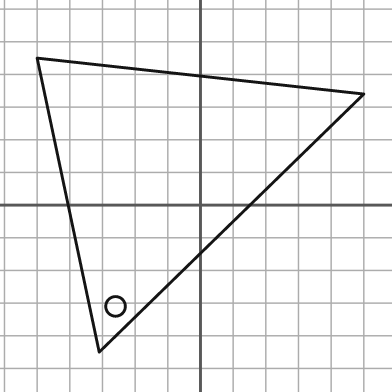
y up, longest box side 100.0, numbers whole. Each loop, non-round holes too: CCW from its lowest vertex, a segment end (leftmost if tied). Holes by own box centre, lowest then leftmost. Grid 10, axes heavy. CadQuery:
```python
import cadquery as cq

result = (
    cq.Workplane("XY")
    .moveTo(-31.0, -45.0)
    .lineTo(50.0, 34.0)
    .lineTo(-50.0, 45.0)
    .close()
    .moveTo(-26.0, -31.0)
    .circle(3.0)
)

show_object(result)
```